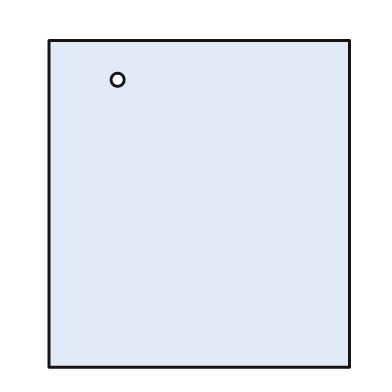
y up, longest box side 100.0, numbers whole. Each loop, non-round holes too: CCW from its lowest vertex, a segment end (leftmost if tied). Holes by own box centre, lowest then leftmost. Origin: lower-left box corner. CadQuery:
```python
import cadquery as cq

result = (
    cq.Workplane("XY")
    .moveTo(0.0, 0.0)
    .lineTo(92.0, 0.0)
    .lineTo(92.0, 100.0)
    .lineTo(0.0, 100.0)
    .close()
    .moveTo(21.0, 88.0)
    .circle(2.0)
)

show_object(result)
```